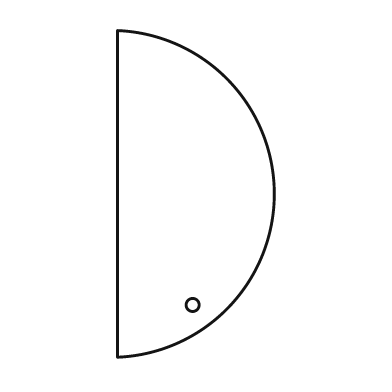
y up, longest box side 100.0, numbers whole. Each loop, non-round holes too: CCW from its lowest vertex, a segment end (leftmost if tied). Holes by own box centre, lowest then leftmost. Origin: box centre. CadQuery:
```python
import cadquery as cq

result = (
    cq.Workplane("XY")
    .moveTo(-24.0, -50.0)
    .threePointArc((24.0, 0.0), (-24.0, 50.0))
    .close()
    .moveTo(-1.0, -34.0)
    .circle(2.0)
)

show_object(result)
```